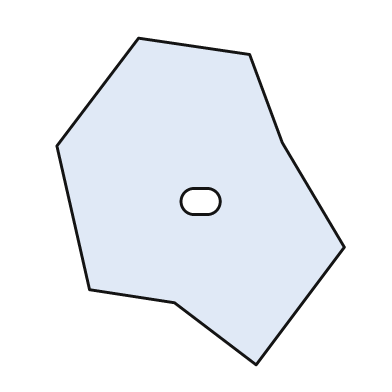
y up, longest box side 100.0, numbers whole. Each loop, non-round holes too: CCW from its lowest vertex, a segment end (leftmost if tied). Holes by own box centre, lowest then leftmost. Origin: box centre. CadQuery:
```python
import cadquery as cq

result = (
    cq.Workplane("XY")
    .moveTo(17.0, -50.0)
    .lineTo(44.0, -14.0)
    .lineTo(25.0, 18.0)
    .lineTo(15.0, 45.0)
    .lineTo(-19.0, 50.0)
    .lineTo(-44.0, 17.0)
    .lineTo(-34.0, -27.0)
    .lineTo(-8.0, -31.0)
    .close()
    .moveTo(-2.0, -4.0)
    .lineTo(2.0, -4.0)
    .threePointArc((6.0, 0.0), (2.0, 4.0))
    .lineTo(-2.0, 4.0)
    .threePointArc((-6.0, 0.0), (-2.0, -4.0))
    .close()
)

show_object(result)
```